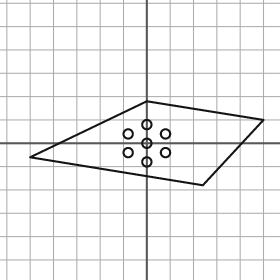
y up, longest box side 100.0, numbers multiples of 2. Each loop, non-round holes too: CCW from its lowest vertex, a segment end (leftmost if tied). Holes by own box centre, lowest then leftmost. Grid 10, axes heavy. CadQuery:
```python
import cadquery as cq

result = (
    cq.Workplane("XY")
    .moveTo(24.0, -18.0)
    .lineTo(50.0, 10.0)
    .lineTo(0.0, 18.0)
    .lineTo(-50.0, -6.0)
    .close()
    .moveTo(0.0, -8.0)
    .circle(2.0)
    .moveTo(-8.0, -4.0)
    .circle(2.0)
    .moveTo(8.0, -4.0)
    .circle(2.0)
    .moveTo(0.0, 0.0)
    .circle(2.0)
    .moveTo(-8.0, 4.0)
    .circle(2.0)
    .moveTo(8.0, 4.0)
    .circle(2.0)
    .moveTo(0.0, 8.0)
    .circle(2.0)
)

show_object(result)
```